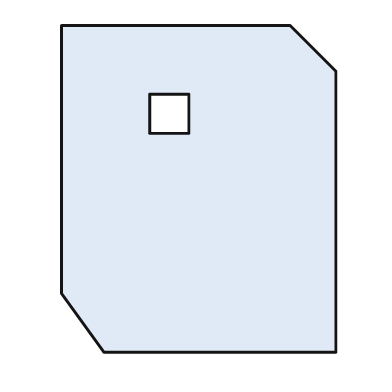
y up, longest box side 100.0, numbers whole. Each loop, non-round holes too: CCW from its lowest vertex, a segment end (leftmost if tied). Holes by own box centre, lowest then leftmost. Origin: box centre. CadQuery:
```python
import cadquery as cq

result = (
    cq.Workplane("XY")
    .moveTo(-29.0, -50.0)
    .lineTo(42.0, -50.0)
    .lineTo(42.0, 36.0)
    .lineTo(28.0, 50.0)
    .lineTo(-42.0, 50.0)
    .lineTo(-42.0, -32.0)
    .close()
    .moveTo(-15.0, 17.0)
    .lineTo(-3.0, 17.0)
    .lineTo(-3.0, 29.0)
    .lineTo(-15.0, 29.0)
    .close()
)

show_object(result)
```